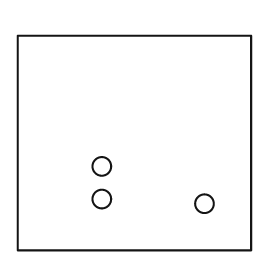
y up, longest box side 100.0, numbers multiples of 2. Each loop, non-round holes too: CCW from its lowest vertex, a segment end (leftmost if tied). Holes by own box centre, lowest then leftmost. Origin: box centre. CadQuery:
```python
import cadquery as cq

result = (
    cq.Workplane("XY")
    .moveTo(-50.0, -46.0)
    .lineTo(50.0, -46.0)
    .lineTo(50.0, 46.0)
    .lineTo(-50.0, 46.0)
    .close()
    .moveTo(30.0, -26.0)
    .circle(4.0)
    .moveTo(-14.0, -24.0)
    .circle(4.0)
    .moveTo(-14.0, -10.0)
    .circle(4.0)
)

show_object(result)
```